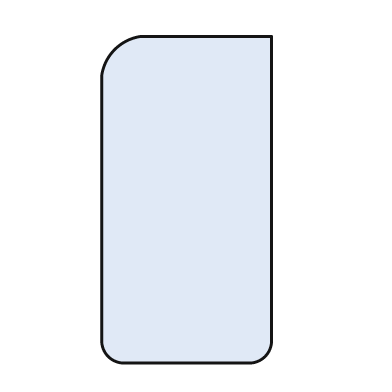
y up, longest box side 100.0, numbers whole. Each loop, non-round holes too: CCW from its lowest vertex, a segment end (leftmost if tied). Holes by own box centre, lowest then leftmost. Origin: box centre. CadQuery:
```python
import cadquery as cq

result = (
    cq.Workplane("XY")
    .moveTo(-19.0, -50.0)
    .lineTo(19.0, -50.0)
    .threePointArc((24.0, -48.0), (26.0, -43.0))
    .lineTo(26.0, 50.0)
    .lineTo(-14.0, 50.0)
    .threePointArc((-22.0, 46.0), (-26.0, 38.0))
    .lineTo(-26.0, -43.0)
    .threePointArc((-24.0, -48.0), (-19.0, -50.0))
    .close()
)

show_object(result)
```